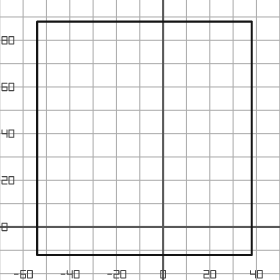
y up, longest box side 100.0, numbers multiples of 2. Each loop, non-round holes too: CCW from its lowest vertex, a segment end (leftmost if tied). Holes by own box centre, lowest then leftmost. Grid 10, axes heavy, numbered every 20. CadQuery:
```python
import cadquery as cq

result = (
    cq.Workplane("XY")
    .moveTo(-54.0, -12.0)
    .lineTo(38.0, -12.0)
    .lineTo(38.0, 88.0)
    .lineTo(-54.0, 88.0)
    .close()
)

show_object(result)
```